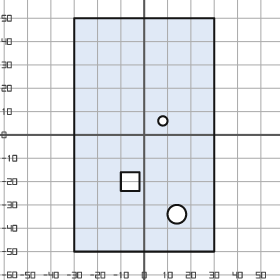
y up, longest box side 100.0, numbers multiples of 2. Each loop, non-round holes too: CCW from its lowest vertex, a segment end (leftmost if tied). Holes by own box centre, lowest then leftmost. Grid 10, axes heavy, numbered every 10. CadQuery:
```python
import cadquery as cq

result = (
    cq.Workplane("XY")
    .moveTo(-30.0, -50.0)
    .lineTo(30.0, -50.0)
    .lineTo(30.0, 50.0)
    .lineTo(-30.0, 50.0)
    .close()
    .moveTo(14.0, -34.0)
    .circle(4.0)
    .moveTo(-10.0, -24.0)
    .lineTo(-2.0, -24.0)
    .lineTo(-2.0, -16.0)
    .lineTo(-10.0, -16.0)
    .close()
    .moveTo(8.0, 6.0)
    .circle(2.0)
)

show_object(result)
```